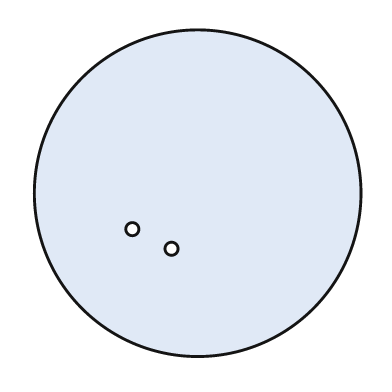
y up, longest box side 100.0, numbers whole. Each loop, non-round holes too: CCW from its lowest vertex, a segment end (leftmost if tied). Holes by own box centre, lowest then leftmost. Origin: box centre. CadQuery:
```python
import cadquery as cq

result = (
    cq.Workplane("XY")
    .moveTo(0.0, 0.0)
    .circle(50.0)
    .moveTo(-8.0, -17.0)
    .circle(2.0)
    .moveTo(-20.0, -11.0)
    .circle(2.0)
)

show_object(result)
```